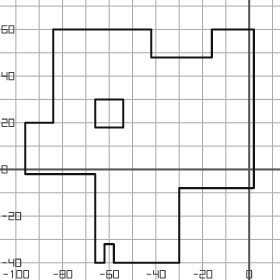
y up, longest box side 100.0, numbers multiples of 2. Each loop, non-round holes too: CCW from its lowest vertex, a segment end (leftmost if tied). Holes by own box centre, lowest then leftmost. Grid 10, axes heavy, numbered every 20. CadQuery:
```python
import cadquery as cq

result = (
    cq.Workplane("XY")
    .moveTo(-66.0, -40.0)
    .lineTo(-62.0, -40.0)
    .lineTo(-62.0, -32.0)
    .lineTo(-58.0, -32.0)
    .lineTo(-58.0, -40.0)
    .lineTo(-30.0, -40.0)
    .lineTo(-30.0, -8.0)
    .lineTo(2.0, -8.0)
    .lineTo(2.0, 60.0)
    .lineTo(-16.0, 60.0)
    .lineTo(-16.0, 48.0)
    .lineTo(-42.0, 48.0)
    .lineTo(-42.0, 60.0)
    .lineTo(-84.0, 60.0)
    .lineTo(-84.0, 20.0)
    .lineTo(-96.0, 20.0)
    .lineTo(-96.0, -2.0)
    .lineTo(-66.0, -2.0)
    .close()
    .moveTo(-66.0, 18.0)
    .lineTo(-54.0, 18.0)
    .lineTo(-54.0, 30.0)
    .lineTo(-66.0, 30.0)
    .close()
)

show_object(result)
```